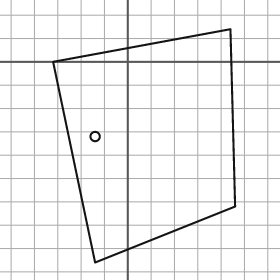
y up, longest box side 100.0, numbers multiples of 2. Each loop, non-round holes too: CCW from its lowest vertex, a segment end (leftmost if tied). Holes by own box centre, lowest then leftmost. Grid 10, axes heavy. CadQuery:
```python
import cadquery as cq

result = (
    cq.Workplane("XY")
    .moveTo(-14.0, -86.0)
    .lineTo(46.0, -62.0)
    .lineTo(44.0, 14.0)
    .lineTo(-32.0, 0.0)
    .close()
    .moveTo(-14.0, -32.0)
    .circle(2.0)
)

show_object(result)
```